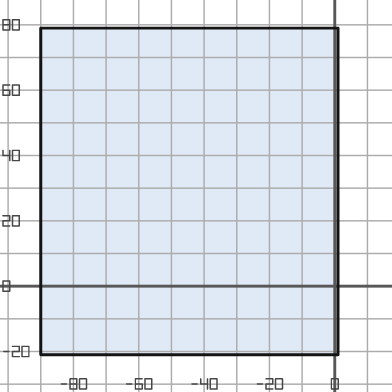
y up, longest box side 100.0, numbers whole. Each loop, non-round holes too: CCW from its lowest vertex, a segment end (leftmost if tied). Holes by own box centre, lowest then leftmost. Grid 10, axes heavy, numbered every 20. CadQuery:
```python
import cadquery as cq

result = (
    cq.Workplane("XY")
    .moveTo(-90.0, -21.0)
    .lineTo(1.0, -21.0)
    .lineTo(1.0, 79.0)
    .lineTo(-90.0, 79.0)
    .close()
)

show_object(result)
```